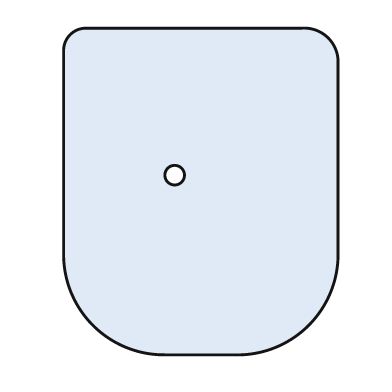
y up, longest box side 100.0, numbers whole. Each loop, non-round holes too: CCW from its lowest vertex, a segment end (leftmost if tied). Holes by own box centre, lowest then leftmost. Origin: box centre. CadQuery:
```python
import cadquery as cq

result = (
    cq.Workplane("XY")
    .moveTo(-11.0, -50.0)
    .lineTo(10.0, -50.0)
    .threePointArc((33.0, -41.0), (42.0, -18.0))
    .lineTo(42.0, 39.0)
    .threePointArc((39.0, 47.0), (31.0, 50.0))
    .lineTo(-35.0, 50.0)
    .threePointArc((-40.0, 48.0), (-42.0, 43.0))
    .lineTo(-42.0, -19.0)
    .threePointArc((-33.0, -41.0), (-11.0, -50.0))
    .close()
    .moveTo(-8.0, 5.0)
    .circle(3.0)
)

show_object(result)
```